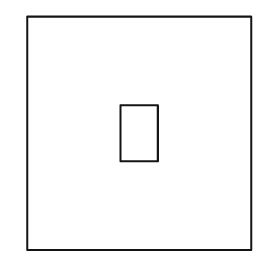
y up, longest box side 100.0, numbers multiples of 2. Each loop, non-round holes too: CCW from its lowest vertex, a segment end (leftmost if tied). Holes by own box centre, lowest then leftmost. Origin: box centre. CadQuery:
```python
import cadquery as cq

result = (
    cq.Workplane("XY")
    .moveTo(-48.0, -50.0)
    .lineTo(48.0, -50.0)
    .lineTo(48.0, 50.0)
    .lineTo(-48.0, 50.0)
    .close()
    .moveTo(-8.0, -12.0)
    .lineTo(8.0, -12.0)
    .lineTo(8.0, 12.0)
    .lineTo(-8.0, 12.0)
    .close()
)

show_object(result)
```